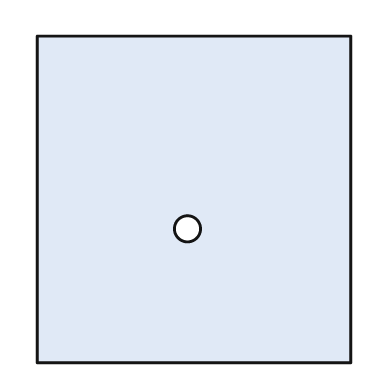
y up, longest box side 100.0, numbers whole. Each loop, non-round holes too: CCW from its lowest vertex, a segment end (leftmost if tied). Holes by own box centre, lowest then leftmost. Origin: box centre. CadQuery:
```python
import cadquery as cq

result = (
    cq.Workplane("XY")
    .moveTo(-48.0, -50.0)
    .lineTo(48.0, -50.0)
    .lineTo(48.0, 50.0)
    .lineTo(-48.0, 50.0)
    .close()
    .moveTo(-2.0, -9.0)
    .circle(4.0)
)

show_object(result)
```